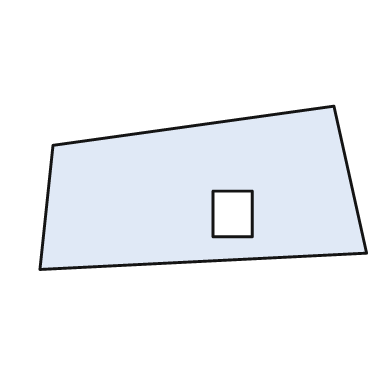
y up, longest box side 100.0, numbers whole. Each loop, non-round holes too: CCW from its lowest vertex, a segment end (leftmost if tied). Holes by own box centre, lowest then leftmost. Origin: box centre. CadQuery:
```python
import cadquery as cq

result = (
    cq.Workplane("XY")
    .moveTo(-50.0, -25.0)
    .lineTo(50.0, -20.0)
    .lineTo(40.0, 25.0)
    .lineTo(-46.0, 13.0)
    .close()
    .moveTo(3.0, -15.0)
    .lineTo(15.0, -15.0)
    .lineTo(15.0, -1.0)
    .lineTo(3.0, -1.0)
    .close()
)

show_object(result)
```